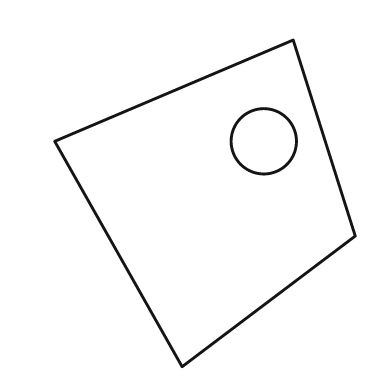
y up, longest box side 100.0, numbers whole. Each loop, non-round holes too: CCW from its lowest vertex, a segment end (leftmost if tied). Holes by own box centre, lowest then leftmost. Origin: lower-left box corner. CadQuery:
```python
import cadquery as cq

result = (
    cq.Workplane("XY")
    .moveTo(39.0, 0.0)
    .lineTo(92.0, 40.0)
    .lineTo(73.0, 100.0)
    .lineTo(0.0, 69.0)
    .close()
    .moveTo(64.0, 69.0)
    .circle(10.0)
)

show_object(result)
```